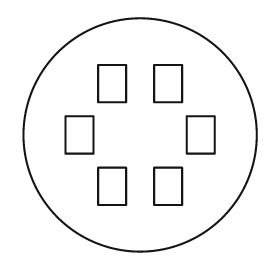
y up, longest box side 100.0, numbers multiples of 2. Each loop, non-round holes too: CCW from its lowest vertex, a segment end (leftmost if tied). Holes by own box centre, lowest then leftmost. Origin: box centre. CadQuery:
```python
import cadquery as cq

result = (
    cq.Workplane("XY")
    .moveTo(0.0, 0.0)
    .circle(50.0)
    .moveTo(-18.0, -30.0)
    .lineTo(-6.0, -30.0)
    .lineTo(-6.0, -14.0)
    .lineTo(-18.0, -14.0)
    .close()
    .moveTo(6.0, -30.0)
    .lineTo(18.0, -30.0)
    .lineTo(18.0, -14.0)
    .lineTo(6.0, -14.0)
    .close()
    .moveTo(-32.0, -8.0)
    .lineTo(-20.0, -8.0)
    .lineTo(-20.0, 8.0)
    .lineTo(-32.0, 8.0)
    .close()
    .moveTo(20.0, -8.0)
    .lineTo(32.0, -8.0)
    .lineTo(32.0, 8.0)
    .lineTo(20.0, 8.0)
    .close()
    .moveTo(-18.0, 14.0)
    .lineTo(-6.0, 14.0)
    .lineTo(-6.0, 30.0)
    .lineTo(-18.0, 30.0)
    .close()
    .moveTo(6.0, 14.0)
    .lineTo(18.0, 14.0)
    .lineTo(18.0, 30.0)
    .lineTo(6.0, 30.0)
    .close()
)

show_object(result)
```